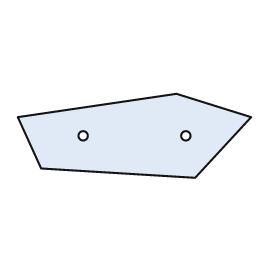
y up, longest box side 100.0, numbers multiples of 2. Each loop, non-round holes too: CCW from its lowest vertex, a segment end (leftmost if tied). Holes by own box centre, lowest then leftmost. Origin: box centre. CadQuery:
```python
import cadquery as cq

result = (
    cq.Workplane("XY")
    .moveTo(26.0, -18.0)
    .lineTo(50.0, 8.0)
    .lineTo(18.0, 18.0)
    .lineTo(-50.0, 8.0)
    .lineTo(-40.0, -14.0)
    .close()
    .moveTo(-22.0, 0.0)
    .circle(2.0)
    .moveTo(22.0, 0.0)
    .circle(2.0)
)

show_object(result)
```